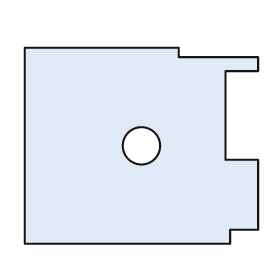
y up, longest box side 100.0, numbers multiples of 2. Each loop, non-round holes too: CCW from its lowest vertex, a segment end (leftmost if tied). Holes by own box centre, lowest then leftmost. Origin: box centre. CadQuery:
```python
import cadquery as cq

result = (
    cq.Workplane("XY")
    .moveTo(-50.0, -42.0)
    .lineTo(38.0, -42.0)
    .lineTo(38.0, -36.0)
    .lineTo(50.0, -36.0)
    .lineTo(50.0, -6.0)
    .lineTo(36.0, -6.0)
    .lineTo(36.0, 32.0)
    .lineTo(50.0, 32.0)
    .lineTo(50.0, 38.0)
    .lineTo(16.0, 38.0)
    .lineTo(16.0, 42.0)
    .lineTo(-50.0, 42.0)
    .close()
    .moveTo(0.0, 0.0)
    .circle(8.0)
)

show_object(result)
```